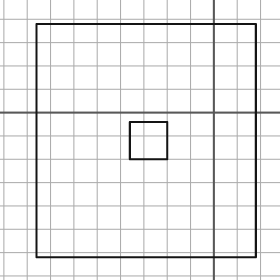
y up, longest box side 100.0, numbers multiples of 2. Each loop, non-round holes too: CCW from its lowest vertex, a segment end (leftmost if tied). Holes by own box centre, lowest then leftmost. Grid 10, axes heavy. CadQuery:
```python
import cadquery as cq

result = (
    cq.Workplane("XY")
    .moveTo(-76.0, -62.0)
    .lineTo(18.0, -62.0)
    .lineTo(18.0, 38.0)
    .lineTo(-76.0, 38.0)
    .close()
    .moveTo(-36.0, -20.0)
    .lineTo(-20.0, -20.0)
    .lineTo(-20.0, -4.0)
    .lineTo(-36.0, -4.0)
    .close()
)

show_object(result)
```